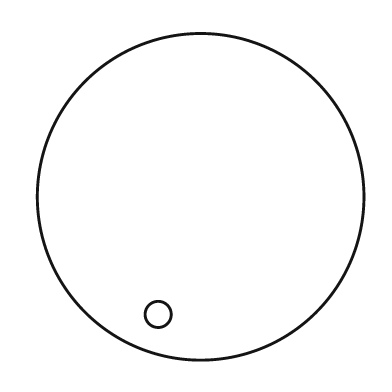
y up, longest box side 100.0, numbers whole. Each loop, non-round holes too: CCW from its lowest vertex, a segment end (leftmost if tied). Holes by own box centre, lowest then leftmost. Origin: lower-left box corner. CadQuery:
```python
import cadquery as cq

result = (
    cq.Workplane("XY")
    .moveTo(50.0, 50.0)
    .circle(50.0)
    .moveTo(37.0, 14.0)
    .circle(4.0)
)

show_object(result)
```